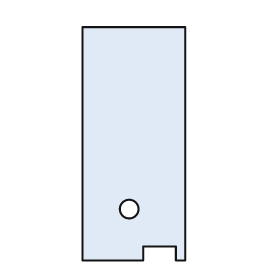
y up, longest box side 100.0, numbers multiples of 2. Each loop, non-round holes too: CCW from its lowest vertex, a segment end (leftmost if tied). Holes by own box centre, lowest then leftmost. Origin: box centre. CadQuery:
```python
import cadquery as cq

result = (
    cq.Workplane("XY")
    .moveTo(-22.0, -50.0)
    .lineTo(4.0, -50.0)
    .lineTo(4.0, -44.0)
    .lineTo(18.0, -44.0)
    .lineTo(18.0, -50.0)
    .lineTo(22.0, -50.0)
    .lineTo(22.0, 50.0)
    .lineTo(-22.0, 50.0)
    .close()
    .moveTo(-2.0, -28.0)
    .circle(4.0)
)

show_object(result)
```